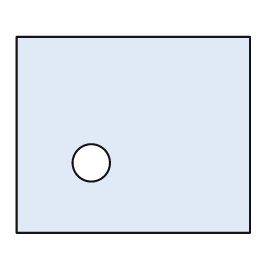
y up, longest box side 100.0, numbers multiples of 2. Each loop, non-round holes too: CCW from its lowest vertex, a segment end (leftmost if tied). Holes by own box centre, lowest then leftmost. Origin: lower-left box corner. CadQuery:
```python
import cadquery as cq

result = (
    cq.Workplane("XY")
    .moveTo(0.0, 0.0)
    .lineTo(100.0, 0.0)
    .lineTo(100.0, 84.0)
    .lineTo(0.0, 84.0)
    .close()
    .moveTo(32.0, 30.0)
    .circle(8.0)
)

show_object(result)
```